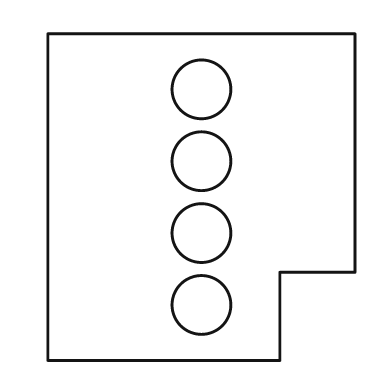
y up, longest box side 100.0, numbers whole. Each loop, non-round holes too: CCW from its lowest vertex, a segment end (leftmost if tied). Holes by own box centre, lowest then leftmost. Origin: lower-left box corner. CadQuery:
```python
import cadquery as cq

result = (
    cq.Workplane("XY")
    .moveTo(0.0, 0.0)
    .lineTo(71.0, 0.0)
    .lineTo(71.0, 27.0)
    .lineTo(94.0, 27.0)
    .lineTo(94.0, 100.0)
    .lineTo(0.0, 100.0)
    .close()
    .moveTo(47.0, 17.0)
    .circle(9.0)
    .moveTo(47.0, 39.0)
    .circle(9.0)
    .moveTo(47.0, 61.0)
    .circle(9.0)
    .moveTo(47.0, 83.0)
    .circle(9.0)
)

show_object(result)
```